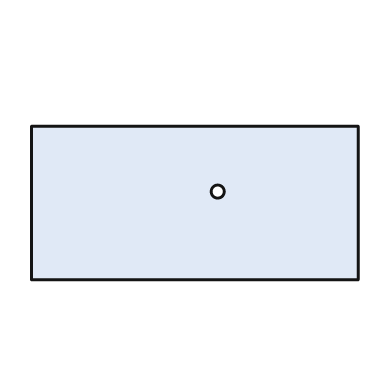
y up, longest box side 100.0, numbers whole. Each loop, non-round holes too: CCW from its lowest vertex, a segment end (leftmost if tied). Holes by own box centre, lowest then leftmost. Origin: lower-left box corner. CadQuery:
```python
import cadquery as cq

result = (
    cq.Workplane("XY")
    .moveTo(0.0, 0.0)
    .lineTo(100.0, 0.0)
    .lineTo(100.0, 47.0)
    .lineTo(0.0, 47.0)
    .close()
    .moveTo(57.0, 27.0)
    .circle(2.0)
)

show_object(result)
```